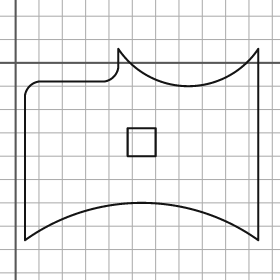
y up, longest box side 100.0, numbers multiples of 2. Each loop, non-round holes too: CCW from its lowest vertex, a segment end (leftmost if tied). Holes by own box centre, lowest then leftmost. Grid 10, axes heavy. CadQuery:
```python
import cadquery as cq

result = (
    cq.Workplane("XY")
    .moveTo(4.0, -76.0)
    .threePointArc((54.0, -60.0), (104.0, -76.0))
    .lineTo(104.0, 6.0)
    .threePointArc((74.0, -10.0), (44.0, 6.0))
    .lineTo(44.0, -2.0)
    .threePointArc((42.0, -6.0), (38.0, -8.0))
    .lineTo(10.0, -8.0)
    .threePointArc((6.0, -10.0), (4.0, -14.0))
    .close()
    .moveTo(48.0, -40.0)
    .lineTo(60.0, -40.0)
    .lineTo(60.0, -28.0)
    .lineTo(48.0, -28.0)
    .close()
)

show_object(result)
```